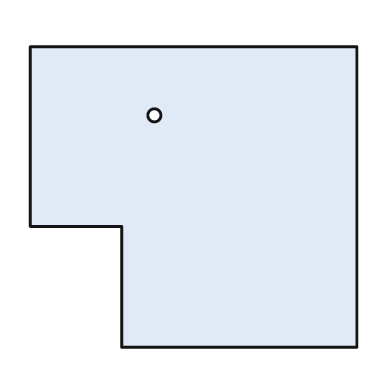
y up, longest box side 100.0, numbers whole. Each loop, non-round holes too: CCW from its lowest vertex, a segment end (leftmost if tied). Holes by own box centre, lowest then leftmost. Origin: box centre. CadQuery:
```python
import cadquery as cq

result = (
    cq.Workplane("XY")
    .moveTo(-22.0, -46.0)
    .lineTo(50.0, -46.0)
    .lineTo(50.0, 46.0)
    .lineTo(-50.0, 46.0)
    .lineTo(-50.0, -9.0)
    .lineTo(-22.0, -9.0)
    .close()
    .moveTo(-12.0, 25.0)
    .circle(2.0)
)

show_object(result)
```